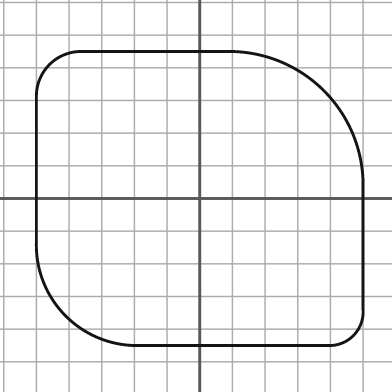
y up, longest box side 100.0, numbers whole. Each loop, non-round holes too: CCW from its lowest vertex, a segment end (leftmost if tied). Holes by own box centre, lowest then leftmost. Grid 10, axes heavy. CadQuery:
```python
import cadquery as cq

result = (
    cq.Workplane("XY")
    .moveTo(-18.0, -45.0)
    .lineTo(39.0, -45.0)
    .threePointArc((47.0, -42.0), (50.0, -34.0))
    .lineTo(50.0, 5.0)
    .threePointArc((38.0, 33.0), (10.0, 45.0))
    .lineTo(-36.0, 45.0)
    .threePointArc((-46.0, 41.0), (-50.0, 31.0))
    .lineTo(-50.0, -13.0)
    .threePointArc((-41.0, -36.0), (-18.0, -45.0))
    .close()
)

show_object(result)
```